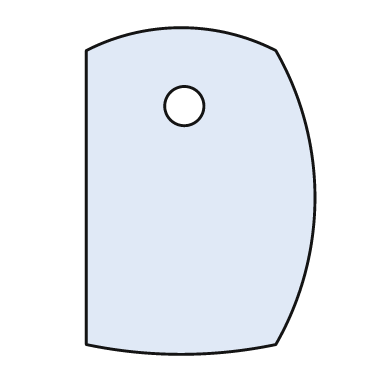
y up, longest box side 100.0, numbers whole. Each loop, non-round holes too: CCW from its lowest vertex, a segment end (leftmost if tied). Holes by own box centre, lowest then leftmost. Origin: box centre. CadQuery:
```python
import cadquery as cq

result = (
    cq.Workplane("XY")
    .moveTo(-35.0, -47.0)
    .threePointArc((-6.0, -50.0), (23.0, -47.0))
    .threePointArc((35.0, -2.0), (23.0, 43.0))
    .threePointArc((-6.0, 50.0), (-35.0, 43.0))
    .close()
    .moveTo(-5.0, 26.0)
    .circle(6.0)
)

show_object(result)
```